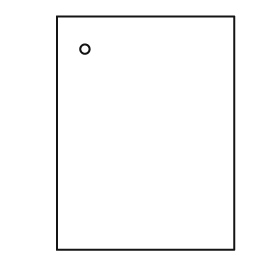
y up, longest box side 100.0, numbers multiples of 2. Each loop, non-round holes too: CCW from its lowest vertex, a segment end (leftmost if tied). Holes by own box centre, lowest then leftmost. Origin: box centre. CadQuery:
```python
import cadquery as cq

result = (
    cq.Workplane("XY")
    .moveTo(-38.0, -50.0)
    .lineTo(38.0, -50.0)
    .lineTo(38.0, 50.0)
    .lineTo(-38.0, 50.0)
    .close()
    .moveTo(-26.0, 36.0)
    .circle(2.0)
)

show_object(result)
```